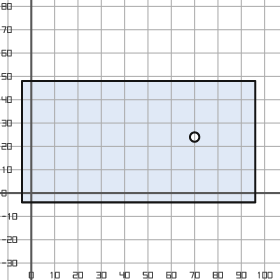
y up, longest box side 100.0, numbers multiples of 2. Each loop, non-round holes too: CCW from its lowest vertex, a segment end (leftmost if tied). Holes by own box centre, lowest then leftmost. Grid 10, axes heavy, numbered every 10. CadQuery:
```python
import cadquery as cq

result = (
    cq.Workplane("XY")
    .moveTo(-4.0, -4.0)
    .lineTo(96.0, -4.0)
    .lineTo(96.0, 48.0)
    .lineTo(-4.0, 48.0)
    .close()
    .moveTo(70.0, 24.0)
    .circle(2.0)
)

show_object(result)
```